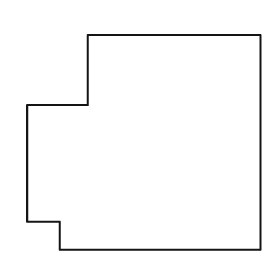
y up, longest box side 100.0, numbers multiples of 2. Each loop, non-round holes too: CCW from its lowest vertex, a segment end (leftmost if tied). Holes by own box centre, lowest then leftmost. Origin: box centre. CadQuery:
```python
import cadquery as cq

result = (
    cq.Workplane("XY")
    .moveTo(-36.0, -46.0)
    .lineTo(50.0, -46.0)
    .lineTo(50.0, 46.0)
    .lineTo(-24.0, 46.0)
    .lineTo(-24.0, 16.0)
    .lineTo(-50.0, 16.0)
    .lineTo(-50.0, -34.0)
    .lineTo(-36.0, -34.0)
    .close()
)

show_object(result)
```